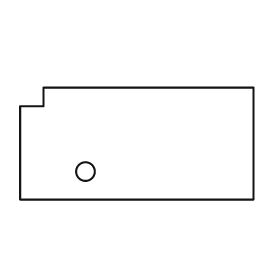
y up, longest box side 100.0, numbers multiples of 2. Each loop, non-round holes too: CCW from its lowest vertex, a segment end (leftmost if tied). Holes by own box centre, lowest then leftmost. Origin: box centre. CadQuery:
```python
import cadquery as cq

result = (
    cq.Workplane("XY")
    .moveTo(-50.0, -24.0)
    .lineTo(50.0, -24.0)
    .lineTo(50.0, 24.0)
    .lineTo(-40.0, 24.0)
    .lineTo(-40.0, 16.0)
    .lineTo(-50.0, 16.0)
    .close()
    .moveTo(-22.0, -12.0)
    .circle(4.0)
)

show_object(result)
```